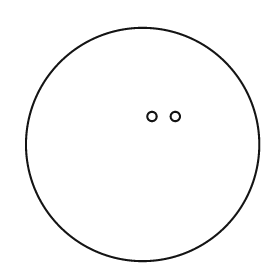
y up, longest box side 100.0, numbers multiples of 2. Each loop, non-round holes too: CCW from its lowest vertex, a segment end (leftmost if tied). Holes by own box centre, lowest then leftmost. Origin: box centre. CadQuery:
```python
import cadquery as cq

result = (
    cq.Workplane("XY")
    .moveTo(0.0, 0.0)
    .circle(50.0)
    .moveTo(4.0, 12.0)
    .circle(2.0)
    .moveTo(14.0, 12.0)
    .circle(2.0)
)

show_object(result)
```